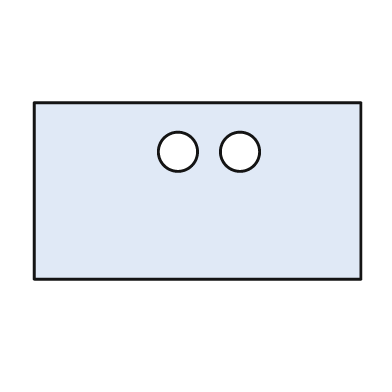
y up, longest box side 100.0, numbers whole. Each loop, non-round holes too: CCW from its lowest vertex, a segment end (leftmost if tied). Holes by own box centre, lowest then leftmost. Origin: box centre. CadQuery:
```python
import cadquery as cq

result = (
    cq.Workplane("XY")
    .moveTo(-50.0, -27.0)
    .lineTo(50.0, -27.0)
    .lineTo(50.0, 27.0)
    .lineTo(-50.0, 27.0)
    .close()
    .moveTo(-6.0, 12.0)
    .circle(6.0)
    .moveTo(13.0, 12.0)
    .circle(6.0)
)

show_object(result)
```